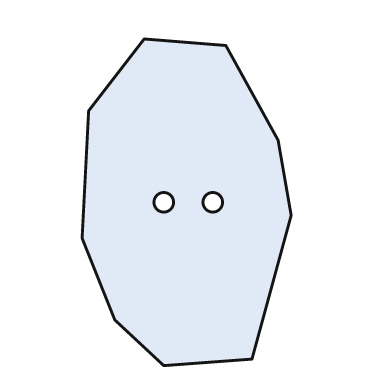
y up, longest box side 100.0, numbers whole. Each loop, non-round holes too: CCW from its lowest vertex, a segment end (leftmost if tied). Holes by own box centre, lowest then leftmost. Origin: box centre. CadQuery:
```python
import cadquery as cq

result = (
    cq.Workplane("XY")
    .moveTo(-7.0, -50.0)
    .lineTo(20.0, -48.0)
    .lineTo(32.0, -4.0)
    .lineTo(28.0, 19.0)
    .lineTo(12.0, 48.0)
    .lineTo(-13.0, 50.0)
    .lineTo(-30.0, 28.0)
    .lineTo(-32.0, -11.0)
    .lineTo(-22.0, -36.0)
    .close()
    .moveTo(-7.0, 0.0)
    .circle(3.0)
    .moveTo(8.0, 0.0)
    .circle(3.0)
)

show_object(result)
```